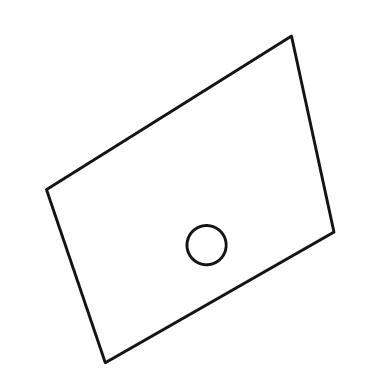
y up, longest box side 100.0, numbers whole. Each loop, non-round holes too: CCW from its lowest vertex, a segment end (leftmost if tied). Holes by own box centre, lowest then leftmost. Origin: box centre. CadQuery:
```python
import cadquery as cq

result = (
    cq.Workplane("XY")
    .moveTo(-26.0, -50.0)
    .lineTo(44.0, -10.0)
    .lineTo(31.0, 50.0)
    .lineTo(-44.0, 3.0)
    .close()
    .moveTo(5.0, -14.0)
    .circle(6.0)
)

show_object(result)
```